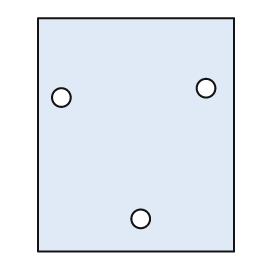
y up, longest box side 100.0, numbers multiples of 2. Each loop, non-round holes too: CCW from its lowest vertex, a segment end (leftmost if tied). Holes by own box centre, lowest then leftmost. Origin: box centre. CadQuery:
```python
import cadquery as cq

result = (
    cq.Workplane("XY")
    .moveTo(-42.0, -50.0)
    .lineTo(42.0, -50.0)
    .lineTo(42.0, 50.0)
    .lineTo(-42.0, 50.0)
    .close()
    .moveTo(2.0, -36.0)
    .circle(4.0)
    .moveTo(-32.0, 16.0)
    .circle(4.0)
    .moveTo(30.0, 20.0)
    .circle(4.0)
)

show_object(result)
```